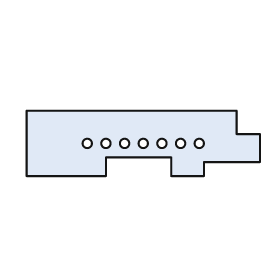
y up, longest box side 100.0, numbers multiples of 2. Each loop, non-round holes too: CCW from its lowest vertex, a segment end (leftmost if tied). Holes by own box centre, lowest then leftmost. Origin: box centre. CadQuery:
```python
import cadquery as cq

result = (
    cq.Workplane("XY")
    .moveTo(-50.0, -14.0)
    .lineTo(-16.0, -14.0)
    .lineTo(-16.0, -6.0)
    .lineTo(12.0, -6.0)
    .lineTo(12.0, -14.0)
    .lineTo(26.0, -14.0)
    .lineTo(26.0, -8.0)
    .lineTo(50.0, -8.0)
    .lineTo(50.0, 4.0)
    .lineTo(40.0, 4.0)
    .lineTo(40.0, 14.0)
    .lineTo(-50.0, 14.0)
    .close()
    .moveTo(-24.0, 0.0)
    .circle(2.0)
    .moveTo(-16.0, 0.0)
    .circle(2.0)
    .moveTo(-8.0, 0.0)
    .circle(2.0)
    .moveTo(0.0, 0.0)
    .circle(2.0)
    .moveTo(8.0, 0.0)
    .circle(2.0)
    .moveTo(16.0, 0.0)
    .circle(2.0)
    .moveTo(24.0, 0.0)
    .circle(2.0)
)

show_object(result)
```